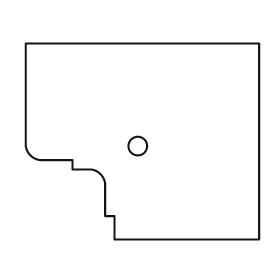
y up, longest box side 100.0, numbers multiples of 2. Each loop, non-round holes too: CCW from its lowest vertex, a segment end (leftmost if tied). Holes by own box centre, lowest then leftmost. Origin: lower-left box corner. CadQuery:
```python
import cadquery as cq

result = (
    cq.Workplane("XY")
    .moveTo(38.0, 0.0)
    .lineTo(100.0, 0.0)
    .lineTo(100.0, 84.0)
    .lineTo(0.0, 84.0)
    .lineTo(0.0, 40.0)
    .threePointArc((2.0, 36.0), (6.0, 34.0))
    .lineTo(20.0, 34.0)
    .lineTo(20.0, 30.0)
    .lineTo(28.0, 30.0)
    .threePointArc((32.0, 28.0), (34.0, 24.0))
    .lineTo(34.0, 10.0)
    .lineTo(38.0, 10.0)
    .close()
    .moveTo(48.0, 40.0)
    .circle(4.0)
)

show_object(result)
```